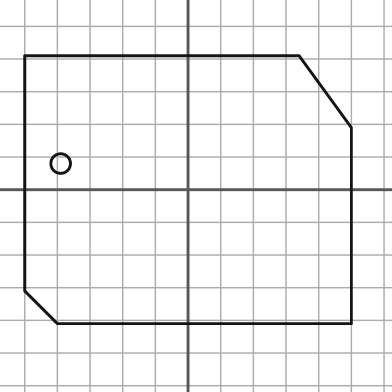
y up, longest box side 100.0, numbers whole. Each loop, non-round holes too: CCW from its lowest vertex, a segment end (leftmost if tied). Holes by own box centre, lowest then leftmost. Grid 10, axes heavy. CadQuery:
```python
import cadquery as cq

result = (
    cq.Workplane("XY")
    .moveTo(-40.0, -41.0)
    .lineTo(50.0, -41.0)
    .lineTo(50.0, 19.0)
    .lineTo(34.0, 41.0)
    .lineTo(-50.0, 41.0)
    .lineTo(-50.0, -31.0)
    .close()
    .moveTo(-39.0, 8.0)
    .circle(3.0)
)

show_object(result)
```